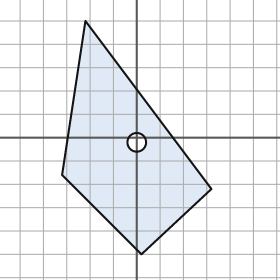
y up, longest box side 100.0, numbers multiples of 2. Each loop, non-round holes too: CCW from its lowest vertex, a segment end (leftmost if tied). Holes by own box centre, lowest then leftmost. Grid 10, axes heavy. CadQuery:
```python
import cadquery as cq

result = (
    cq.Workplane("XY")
    .moveTo(2.0, -50.0)
    .lineTo(32.0, -22.0)
    .lineTo(-22.0, 50.0)
    .lineTo(-32.0, -16.0)
    .close()
    .moveTo(0.0, -2.0)
    .circle(4.0)
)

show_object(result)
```